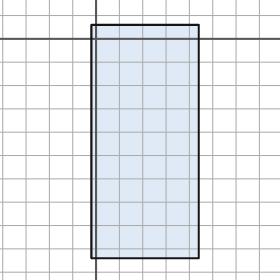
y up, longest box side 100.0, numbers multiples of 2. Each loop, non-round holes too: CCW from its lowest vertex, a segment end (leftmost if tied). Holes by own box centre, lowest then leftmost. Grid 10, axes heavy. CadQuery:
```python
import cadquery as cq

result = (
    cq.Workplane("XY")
    .moveTo(-2.0, -94.0)
    .lineTo(44.0, -94.0)
    .lineTo(44.0, 6.0)
    .lineTo(-2.0, 6.0)
    .close()
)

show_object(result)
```